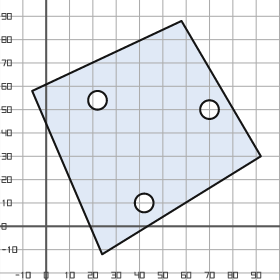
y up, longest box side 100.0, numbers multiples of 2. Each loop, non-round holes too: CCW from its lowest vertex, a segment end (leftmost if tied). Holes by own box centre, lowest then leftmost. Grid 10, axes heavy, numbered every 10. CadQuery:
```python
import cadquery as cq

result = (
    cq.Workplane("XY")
    .moveTo(24.0, -12.0)
    .lineTo(92.0, 30.0)
    .lineTo(58.0, 88.0)
    .lineTo(-6.0, 58.0)
    .close()
    .moveTo(42.0, 10.0)
    .circle(4.0)
    .moveTo(70.0, 50.0)
    .circle(4.0)
    .moveTo(22.0, 54.0)
    .circle(4.0)
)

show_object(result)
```